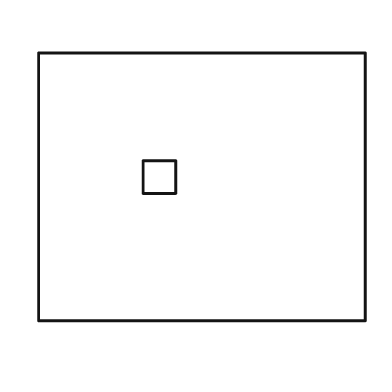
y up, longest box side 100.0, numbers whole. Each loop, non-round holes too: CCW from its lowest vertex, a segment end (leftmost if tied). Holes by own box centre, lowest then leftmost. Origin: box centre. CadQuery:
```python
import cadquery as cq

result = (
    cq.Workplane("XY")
    .moveTo(-50.0, -41.0)
    .lineTo(50.0, -41.0)
    .lineTo(50.0, 41.0)
    .lineTo(-50.0, 41.0)
    .close()
    .moveTo(-18.0, -2.0)
    .lineTo(-8.0, -2.0)
    .lineTo(-8.0, 8.0)
    .lineTo(-18.0, 8.0)
    .close()
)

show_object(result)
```